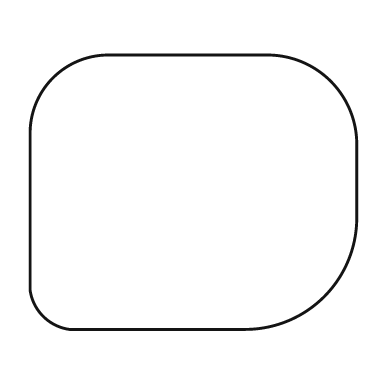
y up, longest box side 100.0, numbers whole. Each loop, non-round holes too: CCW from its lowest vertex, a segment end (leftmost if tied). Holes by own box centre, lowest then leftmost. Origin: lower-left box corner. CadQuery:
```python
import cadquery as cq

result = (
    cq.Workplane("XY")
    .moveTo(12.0, 0.0)
    .lineTo(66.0, 0.0)
    .threePointArc((90.0, 10.0), (100.0, 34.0))
    .lineTo(100.0, 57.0)
    .threePointArc((92.0, 76.0), (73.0, 84.0))
    .lineTo(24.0, 84.0)
    .threePointArc((7.0, 77.0), (0.0, 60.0))
    .lineTo(0.0, 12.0)
    .threePointArc((4.0, 4.0), (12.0, 0.0))
    .close()
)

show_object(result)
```